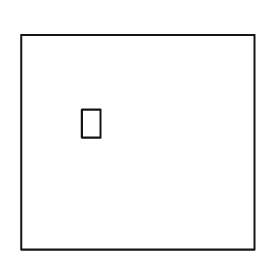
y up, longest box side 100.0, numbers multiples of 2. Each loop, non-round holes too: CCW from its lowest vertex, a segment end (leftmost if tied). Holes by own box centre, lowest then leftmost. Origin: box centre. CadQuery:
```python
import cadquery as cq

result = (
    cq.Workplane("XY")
    .moveTo(-50.0, -46.0)
    .lineTo(50.0, -46.0)
    .lineTo(50.0, 46.0)
    .lineTo(-50.0, 46.0)
    .close()
    .moveTo(-24.0, 2.0)
    .lineTo(-16.0, 2.0)
    .lineTo(-16.0, 14.0)
    .lineTo(-24.0, 14.0)
    .close()
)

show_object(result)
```